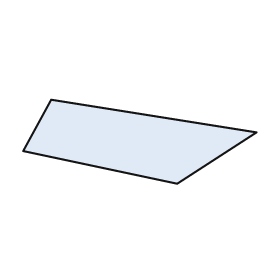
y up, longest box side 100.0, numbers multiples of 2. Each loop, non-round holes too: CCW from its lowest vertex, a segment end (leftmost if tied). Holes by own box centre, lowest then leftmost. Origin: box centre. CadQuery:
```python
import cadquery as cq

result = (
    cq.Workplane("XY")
    .moveTo(16.0, -18.0)
    .lineTo(50.0, 4.0)
    .lineTo(-38.0, 18.0)
    .lineTo(-50.0, -4.0)
    .close()
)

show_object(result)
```